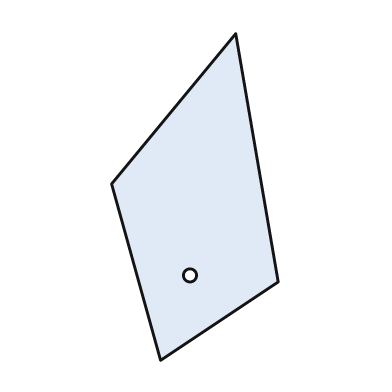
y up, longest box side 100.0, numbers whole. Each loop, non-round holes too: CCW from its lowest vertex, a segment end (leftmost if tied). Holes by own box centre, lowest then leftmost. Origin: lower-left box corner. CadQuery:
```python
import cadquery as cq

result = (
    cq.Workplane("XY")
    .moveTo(15.0, 0.0)
    .lineTo(51.0, 24.0)
    .lineTo(38.0, 100.0)
    .lineTo(0.0, 54.0)
    .close()
    .moveTo(24.0, 26.0)
    .circle(2.0)
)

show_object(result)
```